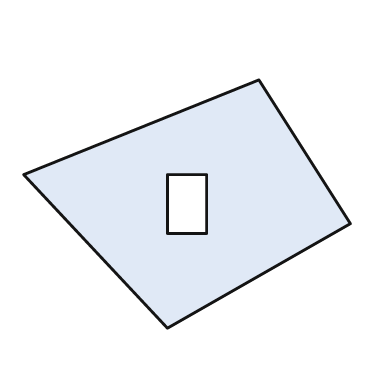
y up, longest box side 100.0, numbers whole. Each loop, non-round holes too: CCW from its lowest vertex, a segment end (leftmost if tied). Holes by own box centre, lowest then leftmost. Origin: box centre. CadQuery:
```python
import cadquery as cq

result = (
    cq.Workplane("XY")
    .moveTo(-6.0, -38.0)
    .lineTo(50.0, -6.0)
    .lineTo(22.0, 38.0)
    .lineTo(-50.0, 9.0)
    .close()
    .moveTo(-6.0, -9.0)
    .lineTo(6.0, -9.0)
    .lineTo(6.0, 9.0)
    .lineTo(-6.0, 9.0)
    .close()
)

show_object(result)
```